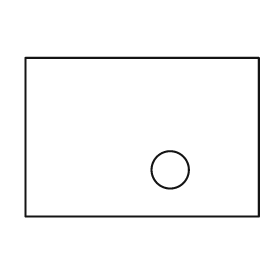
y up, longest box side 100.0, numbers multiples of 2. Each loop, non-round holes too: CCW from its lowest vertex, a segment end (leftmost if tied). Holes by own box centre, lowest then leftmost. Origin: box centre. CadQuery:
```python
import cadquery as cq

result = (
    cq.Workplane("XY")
    .moveTo(-50.0, -34.0)
    .lineTo(50.0, -34.0)
    .lineTo(50.0, 34.0)
    .lineTo(-50.0, 34.0)
    .close()
    .moveTo(12.0, -14.0)
    .circle(8.0)
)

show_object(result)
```